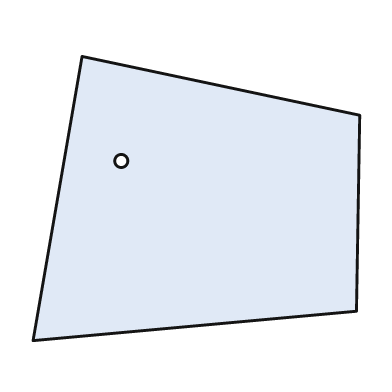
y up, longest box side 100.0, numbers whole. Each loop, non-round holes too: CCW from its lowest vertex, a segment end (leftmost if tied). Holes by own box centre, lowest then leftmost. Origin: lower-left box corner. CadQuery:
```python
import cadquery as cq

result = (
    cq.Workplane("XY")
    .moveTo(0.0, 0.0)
    .lineTo(99.0, 9.0)
    .lineTo(100.0, 69.0)
    .lineTo(15.0, 87.0)
    .close()
    .moveTo(27.0, 55.0)
    .circle(2.0)
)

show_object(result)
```